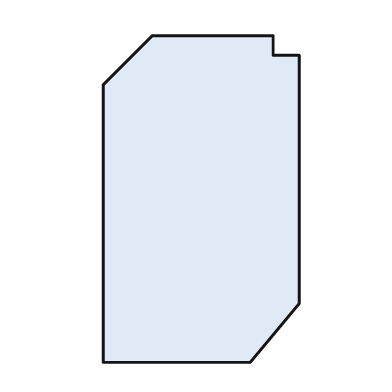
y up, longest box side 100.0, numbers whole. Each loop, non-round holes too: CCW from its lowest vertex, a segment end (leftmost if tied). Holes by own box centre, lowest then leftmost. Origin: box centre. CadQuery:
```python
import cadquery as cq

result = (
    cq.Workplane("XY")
    .moveTo(-30.0, -50.0)
    .lineTo(15.0, -50.0)
    .lineTo(30.0, -32.0)
    .lineTo(30.0, 44.0)
    .lineTo(22.0, 44.0)
    .lineTo(22.0, 50.0)
    .lineTo(-15.0, 50.0)
    .lineTo(-30.0, 35.0)
    .close()
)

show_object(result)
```